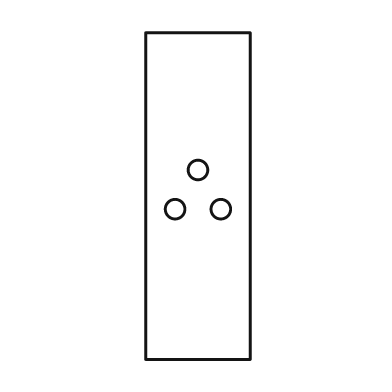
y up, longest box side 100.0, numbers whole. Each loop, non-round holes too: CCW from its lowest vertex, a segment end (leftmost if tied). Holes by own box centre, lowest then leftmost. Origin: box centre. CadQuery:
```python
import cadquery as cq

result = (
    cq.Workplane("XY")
    .moveTo(-16.0, -50.0)
    .lineTo(16.0, -50.0)
    .lineTo(16.0, 50.0)
    .lineTo(-16.0, 50.0)
    .close()
    .moveTo(-7.0, -4.0)
    .circle(3.0)
    .moveTo(7.0, -4.0)
    .circle(3.0)
    .moveTo(0.0, 8.0)
    .circle(3.0)
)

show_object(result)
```